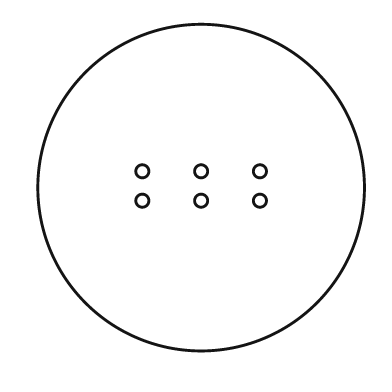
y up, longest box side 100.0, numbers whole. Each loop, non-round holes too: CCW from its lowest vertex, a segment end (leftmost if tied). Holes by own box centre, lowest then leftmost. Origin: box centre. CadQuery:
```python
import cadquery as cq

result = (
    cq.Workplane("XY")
    .moveTo(0.0, 0.0)
    .circle(50.0)
    .moveTo(-18.0, -4.0)
    .circle(2.0)
    .moveTo(0.0, -4.0)
    .circle(2.0)
    .moveTo(18.0, -4.0)
    .circle(2.0)
    .moveTo(-18.0, 5.0)
    .circle(2.0)
    .moveTo(0.0, 5.0)
    .circle(2.0)
    .moveTo(18.0, 5.0)
    .circle(2.0)
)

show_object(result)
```